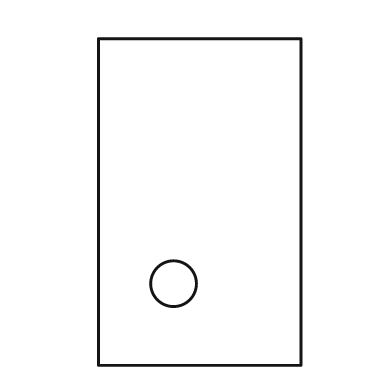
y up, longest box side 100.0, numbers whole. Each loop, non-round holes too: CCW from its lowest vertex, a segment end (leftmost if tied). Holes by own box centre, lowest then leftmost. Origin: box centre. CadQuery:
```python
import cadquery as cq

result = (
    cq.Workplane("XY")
    .moveTo(-31.0, -50.0)
    .lineTo(31.0, -50.0)
    .lineTo(31.0, 50.0)
    .lineTo(-31.0, 50.0)
    .close()
    .moveTo(-8.0, -25.0)
    .circle(7.0)
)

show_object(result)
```